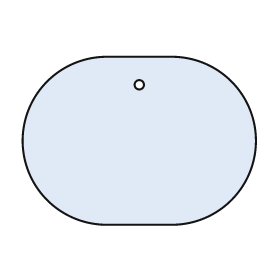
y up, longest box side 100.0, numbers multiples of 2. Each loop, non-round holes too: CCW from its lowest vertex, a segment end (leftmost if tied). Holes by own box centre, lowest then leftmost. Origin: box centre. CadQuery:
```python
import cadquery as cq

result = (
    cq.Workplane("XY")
    .moveTo(-14.0, -36.0)
    .lineTo(14.0, -36.0)
    .threePointArc((50.0, 0.0), (14.0, 36.0))
    .lineTo(-14.0, 36.0)
    .threePointArc((-50.0, 0.0), (-14.0, -36.0))
    .close()
    .moveTo(0.0, 24.0)
    .circle(2.0)
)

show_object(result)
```